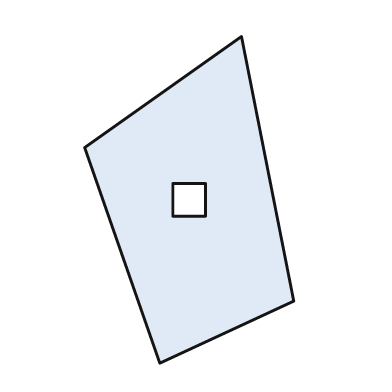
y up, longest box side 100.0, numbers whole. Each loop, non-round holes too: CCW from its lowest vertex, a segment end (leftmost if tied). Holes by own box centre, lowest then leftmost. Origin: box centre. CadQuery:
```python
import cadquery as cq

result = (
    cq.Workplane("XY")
    .moveTo(-9.0, -50.0)
    .lineTo(32.0, -31.0)
    .lineTo(16.0, 50.0)
    .lineTo(-32.0, 16.0)
    .close()
    .moveTo(-5.0, -5.0)
    .lineTo(5.0, -5.0)
    .lineTo(5.0, 5.0)
    .lineTo(-5.0, 5.0)
    .close()
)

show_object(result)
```